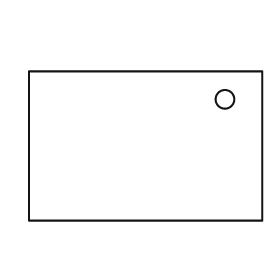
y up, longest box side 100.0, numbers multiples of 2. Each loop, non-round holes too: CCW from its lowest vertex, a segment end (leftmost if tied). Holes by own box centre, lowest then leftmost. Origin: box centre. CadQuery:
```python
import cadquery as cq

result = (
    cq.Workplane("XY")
    .moveTo(-50.0, -32.0)
    .lineTo(50.0, -32.0)
    .lineTo(50.0, 32.0)
    .lineTo(-50.0, 32.0)
    .close()
    .moveTo(34.0, 20.0)
    .circle(4.0)
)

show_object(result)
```